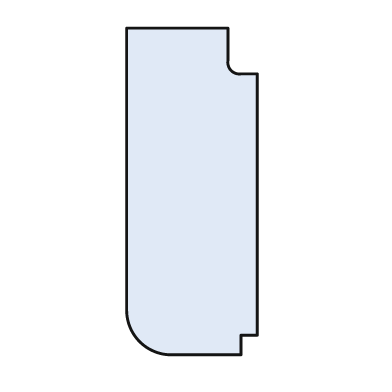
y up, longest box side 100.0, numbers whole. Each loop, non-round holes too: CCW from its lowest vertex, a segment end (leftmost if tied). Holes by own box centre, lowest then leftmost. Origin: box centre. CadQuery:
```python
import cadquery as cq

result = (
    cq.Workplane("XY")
    .moveTo(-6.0, -50.0)
    .lineTo(15.0, -50.0)
    .lineTo(15.0, -44.0)
    .lineTo(20.0, -44.0)
    .lineTo(20.0, 36.0)
    .lineTo(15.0, 36.0)
    .threePointArc((12.0, 37.0), (11.0, 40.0))
    .lineTo(11.0, 50.0)
    .lineTo(-20.0, 50.0)
    .lineTo(-20.0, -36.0)
    .threePointArc((-16.0, -46.0), (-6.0, -50.0))
    .close()
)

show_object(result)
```